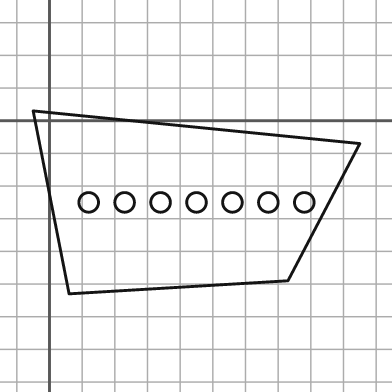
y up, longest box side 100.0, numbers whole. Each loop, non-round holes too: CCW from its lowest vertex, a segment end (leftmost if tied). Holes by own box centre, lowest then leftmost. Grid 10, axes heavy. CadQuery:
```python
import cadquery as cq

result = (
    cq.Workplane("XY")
    .moveTo(6.0, -53.0)
    .lineTo(73.0, -49.0)
    .lineTo(95.0, -7.0)
    .lineTo(-5.0, 3.0)
    .close()
    .moveTo(12.0, -25.0)
    .circle(3.0)
    .moveTo(23.0, -25.0)
    .circle(3.0)
    .moveTo(34.0, -25.0)
    .circle(3.0)
    .moveTo(45.0, -25.0)
    .circle(3.0)
    .moveTo(56.0, -25.0)
    .circle(3.0)
    .moveTo(67.0, -25.0)
    .circle(3.0)
    .moveTo(78.0, -25.0)
    .circle(3.0)
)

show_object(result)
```